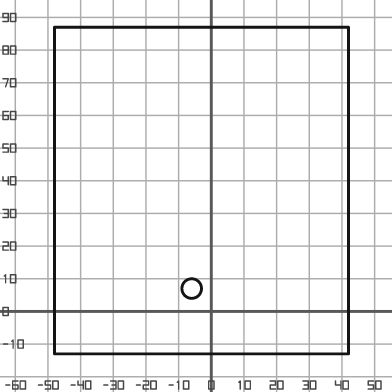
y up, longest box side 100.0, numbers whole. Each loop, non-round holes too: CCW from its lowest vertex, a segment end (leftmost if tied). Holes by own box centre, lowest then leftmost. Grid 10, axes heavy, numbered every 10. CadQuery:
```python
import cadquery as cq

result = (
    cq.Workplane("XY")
    .moveTo(-48.0, -13.0)
    .lineTo(42.0, -13.0)
    .lineTo(42.0, 87.0)
    .lineTo(-48.0, 87.0)
    .close()
    .moveTo(-6.0, 7.0)
    .circle(3.0)
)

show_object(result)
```